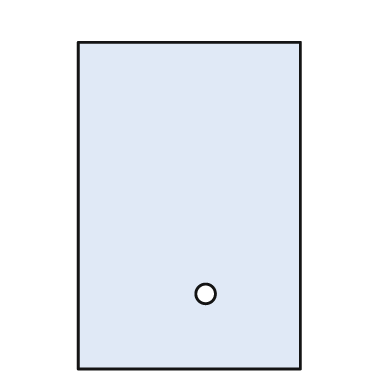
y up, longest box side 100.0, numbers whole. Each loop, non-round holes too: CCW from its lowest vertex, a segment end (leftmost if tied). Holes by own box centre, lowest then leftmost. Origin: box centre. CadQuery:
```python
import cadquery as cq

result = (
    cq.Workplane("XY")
    .moveTo(-34.0, -50.0)
    .lineTo(34.0, -50.0)
    .lineTo(34.0, 50.0)
    .lineTo(-34.0, 50.0)
    .close()
    .moveTo(5.0, -27.0)
    .circle(3.0)
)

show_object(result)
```